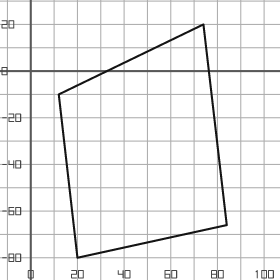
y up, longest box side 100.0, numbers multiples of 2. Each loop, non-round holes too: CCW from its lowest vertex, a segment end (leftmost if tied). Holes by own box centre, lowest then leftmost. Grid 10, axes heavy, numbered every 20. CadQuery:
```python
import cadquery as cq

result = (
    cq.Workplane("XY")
    .moveTo(20.0, -80.0)
    .lineTo(84.0, -66.0)
    .lineTo(74.0, 20.0)
    .lineTo(12.0, -10.0)
    .close()
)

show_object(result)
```